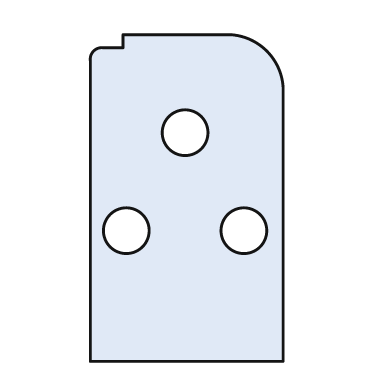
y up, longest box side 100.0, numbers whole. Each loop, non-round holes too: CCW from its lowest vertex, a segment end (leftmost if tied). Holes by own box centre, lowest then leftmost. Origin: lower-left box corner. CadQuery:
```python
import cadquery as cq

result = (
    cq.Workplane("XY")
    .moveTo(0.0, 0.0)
    .lineTo(59.0, 0.0)
    .lineTo(59.0, 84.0)
    .threePointArc((54.0, 95.0), (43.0, 100.0))
    .lineTo(10.0, 100.0)
    .lineTo(10.0, 96.0)
    .lineTo(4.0, 96.0)
    .threePointArc((1.0, 95.0), (0.0, 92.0))
    .close()
    .moveTo(11.0, 40.0)
    .circle(7.0)
    .moveTo(47.0, 40.0)
    .circle(7.0)
    .moveTo(29.0, 70.0)
    .circle(7.0)
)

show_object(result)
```